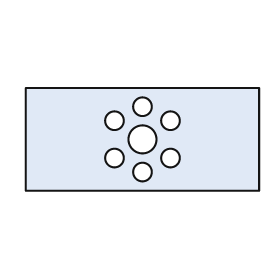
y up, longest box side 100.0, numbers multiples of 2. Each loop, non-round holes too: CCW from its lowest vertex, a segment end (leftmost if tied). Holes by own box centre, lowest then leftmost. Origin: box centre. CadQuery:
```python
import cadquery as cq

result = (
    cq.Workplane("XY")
    .moveTo(-50.0, -22.0)
    .lineTo(50.0, -22.0)
    .lineTo(50.0, 22.0)
    .lineTo(-50.0, 22.0)
    .close()
    .moveTo(0.0, -14.0)
    .circle(4.0)
    .moveTo(-12.0, -8.0)
    .circle(4.0)
    .moveTo(12.0, -8.0)
    .circle(4.0)
    .moveTo(0.0, 0.0)
    .circle(6.0)
    .moveTo(-12.0, 8.0)
    .circle(4.0)
    .moveTo(12.0, 8.0)
    .circle(4.0)
    .moveTo(0.0, 14.0)
    .circle(4.0)
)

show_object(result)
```